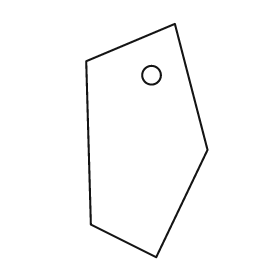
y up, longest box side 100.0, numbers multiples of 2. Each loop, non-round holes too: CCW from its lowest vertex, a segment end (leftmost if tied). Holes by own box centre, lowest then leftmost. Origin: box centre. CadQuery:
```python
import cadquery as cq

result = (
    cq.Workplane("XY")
    .moveTo(4.0, -50.0)
    .lineTo(26.0, -4.0)
    .lineTo(12.0, 50.0)
    .lineTo(-26.0, 34.0)
    .lineTo(-24.0, -36.0)
    .close()
    .moveTo(2.0, 28.0)
    .circle(4.0)
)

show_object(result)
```